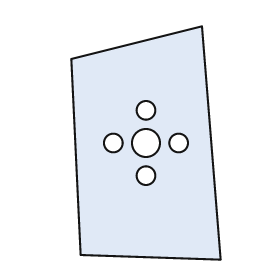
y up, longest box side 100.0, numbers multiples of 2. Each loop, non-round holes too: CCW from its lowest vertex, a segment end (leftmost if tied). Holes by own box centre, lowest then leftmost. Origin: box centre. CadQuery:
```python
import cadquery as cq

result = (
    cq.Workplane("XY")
    .moveTo(32.0, -50.0)
    .lineTo(24.0, 50.0)
    .lineTo(-32.0, 36.0)
    .lineTo(-28.0, -48.0)
    .close()
    .moveTo(0.0, -14.0)
    .circle(4.0)
    .moveTo(-14.0, 0.0)
    .circle(4.0)
    .moveTo(0.0, 0.0)
    .circle(6.0)
    .moveTo(14.0, 0.0)
    .circle(4.0)
    .moveTo(0.0, 14.0)
    .circle(4.0)
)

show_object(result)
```